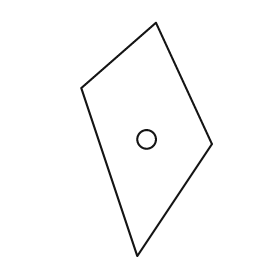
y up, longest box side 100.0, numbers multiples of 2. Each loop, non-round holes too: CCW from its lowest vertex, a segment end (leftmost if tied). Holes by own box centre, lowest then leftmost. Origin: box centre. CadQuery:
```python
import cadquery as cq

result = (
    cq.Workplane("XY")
    .moveTo(-4.0, -50.0)
    .lineTo(28.0, -2.0)
    .lineTo(4.0, 50.0)
    .lineTo(-28.0, 22.0)
    .close()
    .moveTo(0.0, 0.0)
    .circle(4.0)
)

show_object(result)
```